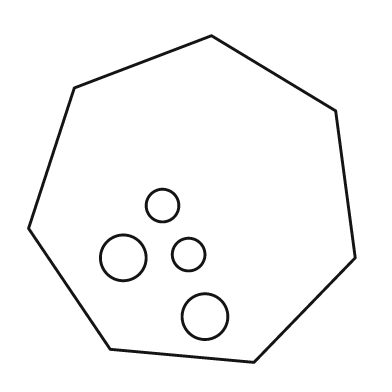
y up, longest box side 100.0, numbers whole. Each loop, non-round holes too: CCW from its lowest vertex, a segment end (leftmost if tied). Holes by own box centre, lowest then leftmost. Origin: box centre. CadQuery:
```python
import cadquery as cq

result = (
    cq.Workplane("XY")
    .moveTo(19.0, -50.0)
    .lineTo(50.0, -18.0)
    .lineTo(44.0, 27.0)
    .lineTo(6.0, 50.0)
    .lineTo(-36.0, 34.0)
    .lineTo(-50.0, -9.0)
    .lineTo(-25.0, -46.0)
    .close()
    .moveTo(4.0, -36.0)
    .circle(7.0)
    .moveTo(-21.0, -18.0)
    .circle(7.0)
    .moveTo(-1.0, -17.0)
    .circle(5.0)
    .moveTo(-9.0, -2.0)
    .circle(5.0)
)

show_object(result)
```